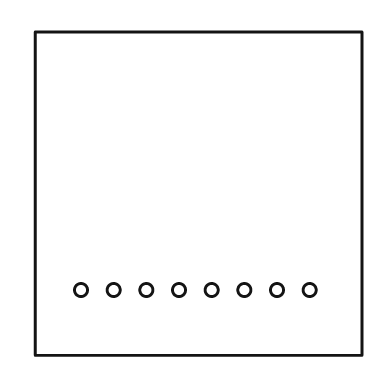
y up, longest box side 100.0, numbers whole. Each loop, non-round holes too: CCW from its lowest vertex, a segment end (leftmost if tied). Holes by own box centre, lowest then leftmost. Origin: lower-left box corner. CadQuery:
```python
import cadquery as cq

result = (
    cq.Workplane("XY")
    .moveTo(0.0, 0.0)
    .lineTo(100.0, 0.0)
    .lineTo(100.0, 99.0)
    .lineTo(0.0, 99.0)
    .close()
    .moveTo(14.0, 20.0)
    .circle(2.0)
    .moveTo(24.0, 20.0)
    .circle(2.0)
    .moveTo(34.0, 20.0)
    .circle(2.0)
    .moveTo(44.0, 20.0)
    .circle(2.0)
    .moveTo(54.0, 20.0)
    .circle(2.0)
    .moveTo(64.0, 20.0)
    .circle(2.0)
    .moveTo(74.0, 20.0)
    .circle(2.0)
    .moveTo(84.0, 20.0)
    .circle(2.0)
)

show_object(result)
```